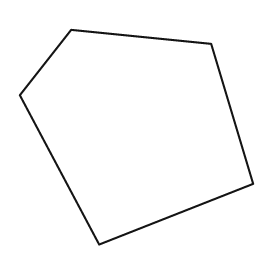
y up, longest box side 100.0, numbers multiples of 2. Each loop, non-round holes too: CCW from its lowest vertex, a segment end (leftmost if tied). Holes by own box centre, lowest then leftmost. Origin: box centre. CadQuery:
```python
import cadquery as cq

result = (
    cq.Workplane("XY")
    .moveTo(-16.0, -46.0)
    .lineTo(50.0, -20.0)
    .lineTo(32.0, 40.0)
    .lineTo(-28.0, 46.0)
    .lineTo(-50.0, 18.0)
    .close()
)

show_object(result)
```